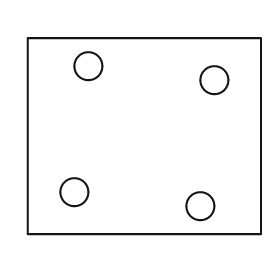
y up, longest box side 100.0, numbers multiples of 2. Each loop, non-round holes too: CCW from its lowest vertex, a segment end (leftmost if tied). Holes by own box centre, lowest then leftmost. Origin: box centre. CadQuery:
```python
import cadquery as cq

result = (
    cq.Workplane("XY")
    .moveTo(-50.0, -42.0)
    .lineTo(50.0, -42.0)
    .lineTo(50.0, 42.0)
    .lineTo(-50.0, 42.0)
    .close()
    .moveTo(24.0, -30.0)
    .circle(6.0)
    .moveTo(-30.0, -24.0)
    .circle(6.0)
    .moveTo(30.0, 24.0)
    .circle(6.0)
    .moveTo(-24.0, 30.0)
    .circle(6.0)
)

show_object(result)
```